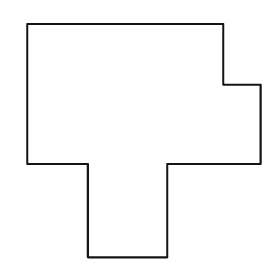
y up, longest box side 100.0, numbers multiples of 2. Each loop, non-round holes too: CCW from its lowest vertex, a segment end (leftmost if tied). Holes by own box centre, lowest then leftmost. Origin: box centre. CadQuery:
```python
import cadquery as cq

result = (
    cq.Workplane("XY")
    .moveTo(-24.0, -50.0)
    .lineTo(10.0, -50.0)
    .lineTo(10.0, -10.0)
    .lineTo(50.0, -10.0)
    .lineTo(50.0, 24.0)
    .lineTo(34.0, 24.0)
    .lineTo(34.0, 50.0)
    .lineTo(-50.0, 50.0)
    .lineTo(-50.0, -10.0)
    .lineTo(-24.0, -10.0)
    .close()
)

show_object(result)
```